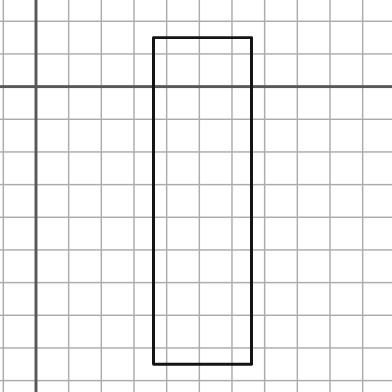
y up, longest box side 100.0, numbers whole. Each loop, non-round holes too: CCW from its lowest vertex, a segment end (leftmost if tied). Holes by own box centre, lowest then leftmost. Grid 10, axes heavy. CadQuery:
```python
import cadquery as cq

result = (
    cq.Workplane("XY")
    .moveTo(36.0, -85.0)
    .lineTo(66.0, -85.0)
    .lineTo(66.0, 15.0)
    .lineTo(36.0, 15.0)
    .close()
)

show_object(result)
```